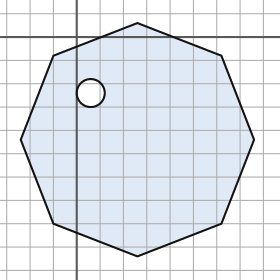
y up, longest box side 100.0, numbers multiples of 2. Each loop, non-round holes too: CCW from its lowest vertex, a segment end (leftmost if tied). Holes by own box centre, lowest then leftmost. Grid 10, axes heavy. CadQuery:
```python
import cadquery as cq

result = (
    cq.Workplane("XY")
    .moveTo(26.0, -94.0)
    .lineTo(62.0, -80.0)
    .lineTo(76.0, -44.0)
    .lineTo(62.0, -8.0)
    .lineTo(26.0, 6.0)
    .lineTo(-10.0, -8.0)
    .lineTo(-24.0, -44.0)
    .lineTo(-10.0, -80.0)
    .close()
    .moveTo(6.0, -24.0)
    .circle(6.0)
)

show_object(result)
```